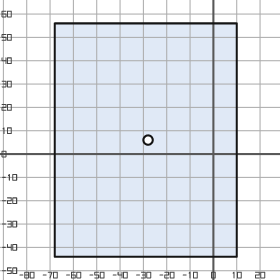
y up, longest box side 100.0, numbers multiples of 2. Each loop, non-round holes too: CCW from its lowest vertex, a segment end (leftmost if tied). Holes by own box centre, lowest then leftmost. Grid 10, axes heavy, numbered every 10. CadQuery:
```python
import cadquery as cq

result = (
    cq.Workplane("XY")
    .moveTo(-68.0, -44.0)
    .lineTo(10.0, -44.0)
    .lineTo(10.0, 56.0)
    .lineTo(-68.0, 56.0)
    .close()
    .moveTo(-28.0, 6.0)
    .circle(2.0)
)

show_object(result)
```